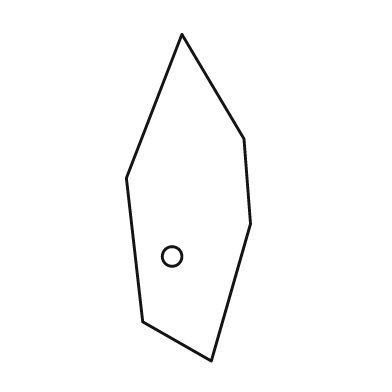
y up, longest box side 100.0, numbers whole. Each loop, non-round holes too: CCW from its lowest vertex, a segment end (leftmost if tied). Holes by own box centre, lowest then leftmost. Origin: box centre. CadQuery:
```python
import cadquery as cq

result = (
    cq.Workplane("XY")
    .moveTo(7.0, -50.0)
    .lineTo(19.0, -8.0)
    .lineTo(17.0, 18.0)
    .lineTo(-2.0, 50.0)
    .lineTo(-19.0, 6.0)
    .lineTo(-14.0, -38.0)
    .close()
    .moveTo(-5.0, -18.0)
    .circle(3.0)
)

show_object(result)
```